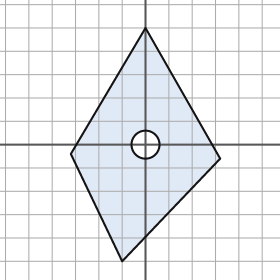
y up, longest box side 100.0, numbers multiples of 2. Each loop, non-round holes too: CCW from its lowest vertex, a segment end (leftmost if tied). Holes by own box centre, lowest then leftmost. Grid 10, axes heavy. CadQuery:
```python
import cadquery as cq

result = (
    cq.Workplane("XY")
    .moveTo(-10.0, -50.0)
    .lineTo(32.0, -6.0)
    .lineTo(0.0, 50.0)
    .lineTo(-32.0, -4.0)
    .close()
    .moveTo(0.0, 0.0)
    .circle(6.0)
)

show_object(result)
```